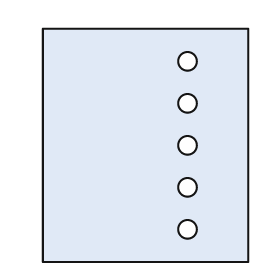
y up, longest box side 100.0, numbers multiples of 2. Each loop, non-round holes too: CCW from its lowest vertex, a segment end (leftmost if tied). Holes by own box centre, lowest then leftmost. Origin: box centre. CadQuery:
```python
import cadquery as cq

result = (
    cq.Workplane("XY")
    .moveTo(-44.0, -50.0)
    .lineTo(44.0, -50.0)
    .lineTo(44.0, 50.0)
    .lineTo(-44.0, 50.0)
    .close()
    .moveTo(18.0, -36.0)
    .circle(4.0)
    .moveTo(18.0, -18.0)
    .circle(4.0)
    .moveTo(18.0, 0.0)
    .circle(4.0)
    .moveTo(18.0, 18.0)
    .circle(4.0)
    .moveTo(18.0, 36.0)
    .circle(4.0)
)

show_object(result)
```